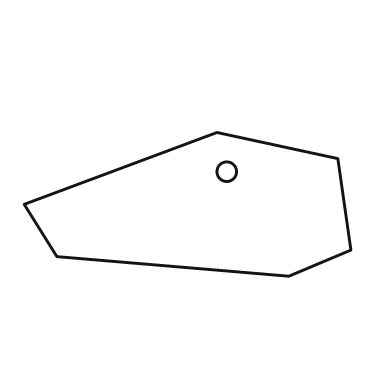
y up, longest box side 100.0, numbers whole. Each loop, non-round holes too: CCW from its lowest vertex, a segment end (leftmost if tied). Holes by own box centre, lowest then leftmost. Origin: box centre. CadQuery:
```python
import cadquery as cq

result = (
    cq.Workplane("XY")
    .moveTo(31.0, -22.0)
    .lineTo(50.0, -14.0)
    .lineTo(46.0, 14.0)
    .lineTo(9.0, 22.0)
    .lineTo(-50.0, 0.0)
    .lineTo(-40.0, -16.0)
    .close()
    .moveTo(12.0, 10.0)
    .circle(3.0)
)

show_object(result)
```